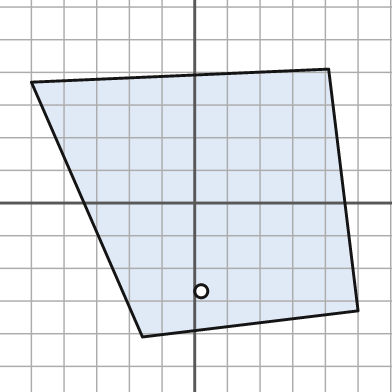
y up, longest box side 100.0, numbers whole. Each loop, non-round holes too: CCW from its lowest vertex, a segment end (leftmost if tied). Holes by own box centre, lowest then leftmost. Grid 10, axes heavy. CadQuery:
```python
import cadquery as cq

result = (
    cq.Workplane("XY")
    .moveTo(-16.0, -41.0)
    .lineTo(50.0, -33.0)
    .lineTo(41.0, 41.0)
    .lineTo(-50.0, 37.0)
    .close()
    .moveTo(2.0, -27.0)
    .circle(2.0)
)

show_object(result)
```